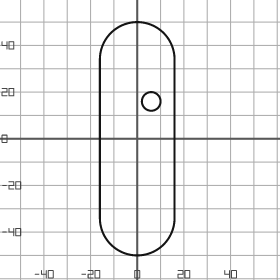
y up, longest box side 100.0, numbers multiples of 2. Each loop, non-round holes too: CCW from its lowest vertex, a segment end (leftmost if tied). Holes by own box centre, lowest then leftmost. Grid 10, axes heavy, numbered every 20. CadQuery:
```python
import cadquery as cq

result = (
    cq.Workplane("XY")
    .moveTo(-16.0, -34.0)
    .threePointArc((0.0, -50.0), (16.0, -34.0))
    .lineTo(16.0, 34.0)
    .threePointArc((0.0, 50.0), (-16.0, 34.0))
    .close()
    .moveTo(6.0, 16.0)
    .circle(4.0)
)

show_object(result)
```